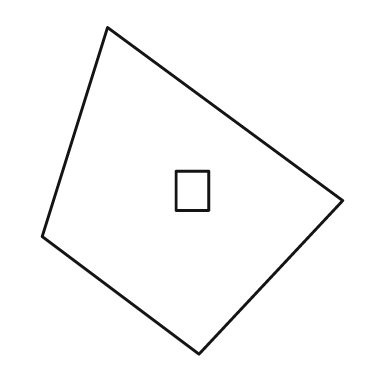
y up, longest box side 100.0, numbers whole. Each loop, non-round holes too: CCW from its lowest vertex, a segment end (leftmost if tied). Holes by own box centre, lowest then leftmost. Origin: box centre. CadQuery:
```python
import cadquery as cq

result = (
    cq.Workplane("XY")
    .moveTo(2.0, -50.0)
    .lineTo(46.0, -3.0)
    .lineTo(-26.0, 50.0)
    .lineTo(-46.0, -14.0)
    .close()
    .moveTo(-5.0, -6.0)
    .lineTo(5.0, -6.0)
    .lineTo(5.0, 6.0)
    .lineTo(-5.0, 6.0)
    .close()
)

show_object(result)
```